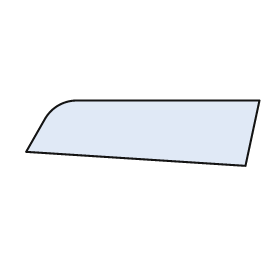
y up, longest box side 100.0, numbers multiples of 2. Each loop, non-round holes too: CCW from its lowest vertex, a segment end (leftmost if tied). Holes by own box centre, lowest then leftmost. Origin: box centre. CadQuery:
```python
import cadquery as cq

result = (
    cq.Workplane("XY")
    .moveTo(44.0, -14.0)
    .lineTo(50.0, 14.0)
    .lineTo(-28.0, 14.0)
    .threePointArc((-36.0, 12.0), (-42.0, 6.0))
    .lineTo(-50.0, -8.0)
    .close()
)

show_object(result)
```